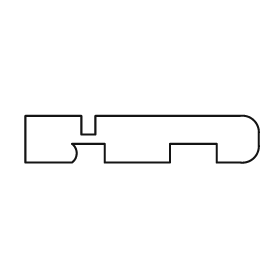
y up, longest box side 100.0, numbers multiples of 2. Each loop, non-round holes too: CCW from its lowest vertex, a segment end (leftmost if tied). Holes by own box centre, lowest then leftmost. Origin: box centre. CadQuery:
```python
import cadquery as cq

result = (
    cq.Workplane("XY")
    .moveTo(-50.0, -10.0)
    .lineTo(-30.0, -10.0)
    .threePointArc((-28.0, -6.0), (-30.0, -2.0))
    .lineTo(-16.0, -2.0)
    .lineTo(-16.0, -10.0)
    .lineTo(12.0, -10.0)
    .lineTo(12.0, -2.0)
    .lineTo(32.0, -2.0)
    .lineTo(32.0, -10.0)
    .lineTo(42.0, -10.0)
    .threePointArc((48.0, -8.0), (50.0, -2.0))
    .lineTo(50.0, 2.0)
    .threePointArc((48.0, 8.0), (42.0, 10.0))
    .lineTo(-20.0, 10.0)
    .lineTo(-20.0, 2.0)
    .lineTo(-26.0, 2.0)
    .lineTo(-26.0, 10.0)
    .lineTo(-50.0, 10.0)
    .close()
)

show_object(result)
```